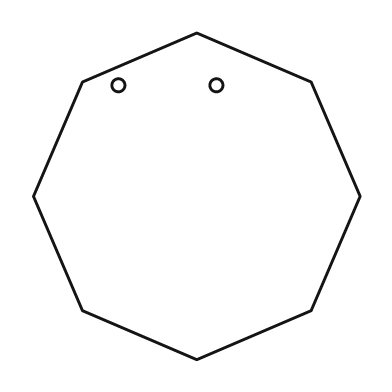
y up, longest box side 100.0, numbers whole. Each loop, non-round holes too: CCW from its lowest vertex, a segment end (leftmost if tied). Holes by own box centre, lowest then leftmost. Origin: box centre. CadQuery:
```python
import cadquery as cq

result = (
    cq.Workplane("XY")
    .moveTo(0.0, -50.0)
    .lineTo(35.0, -35.0)
    .lineTo(50.0, 0.0)
    .lineTo(35.0, 35.0)
    .lineTo(0.0, 50.0)
    .lineTo(-35.0, 35.0)
    .lineTo(-50.0, 0.0)
    .lineTo(-35.0, -35.0)
    .close()
    .moveTo(-24.0, 34.0)
    .circle(2.0)
    .moveTo(6.0, 34.0)
    .circle(2.0)
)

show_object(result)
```